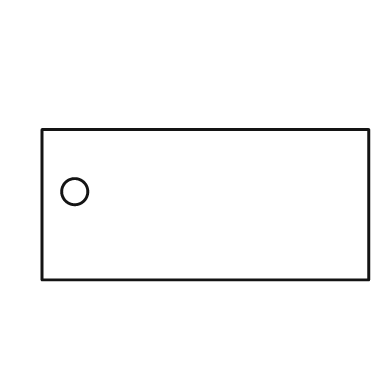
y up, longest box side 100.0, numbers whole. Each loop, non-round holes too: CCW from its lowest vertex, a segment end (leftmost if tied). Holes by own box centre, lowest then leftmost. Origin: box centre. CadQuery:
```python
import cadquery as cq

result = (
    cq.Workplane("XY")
    .moveTo(-50.0, -23.0)
    .lineTo(50.0, -23.0)
    .lineTo(50.0, 23.0)
    .lineTo(-50.0, 23.0)
    .close()
    .moveTo(-40.0, 4.0)
    .circle(4.0)
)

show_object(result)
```